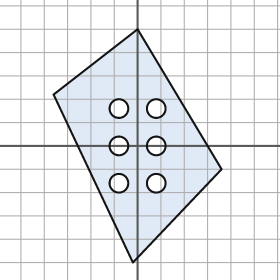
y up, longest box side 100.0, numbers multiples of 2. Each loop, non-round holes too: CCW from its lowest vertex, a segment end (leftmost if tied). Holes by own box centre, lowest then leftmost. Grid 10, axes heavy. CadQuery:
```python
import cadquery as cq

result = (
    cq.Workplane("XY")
    .moveTo(-2.0, -50.0)
    .lineTo(36.0, -10.0)
    .lineTo(0.0, 50.0)
    .lineTo(-36.0, 22.0)
    .close()
    .moveTo(-8.0, -16.0)
    .circle(4.0)
    .moveTo(8.0, -16.0)
    .circle(4.0)
    .moveTo(-8.0, 0.0)
    .circle(4.0)
    .moveTo(8.0, 0.0)
    .circle(4.0)
    .moveTo(-8.0, 16.0)
    .circle(4.0)
    .moveTo(8.0, 16.0)
    .circle(4.0)
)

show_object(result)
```